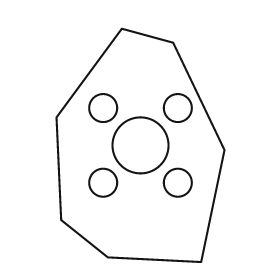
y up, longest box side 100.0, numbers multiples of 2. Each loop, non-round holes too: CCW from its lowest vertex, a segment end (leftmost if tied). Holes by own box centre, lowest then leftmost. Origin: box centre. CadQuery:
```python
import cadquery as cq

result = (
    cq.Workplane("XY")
    .moveTo(26.0, -50.0)
    .lineTo(36.0, -2.0)
    .lineTo(14.0, 44.0)
    .lineTo(-8.0, 50.0)
    .lineTo(-36.0, 12.0)
    .lineTo(-34.0, -32.0)
    .lineTo(-14.0, -48.0)
    .close()
    .moveTo(-16.0, -16.0)
    .circle(6.0)
    .moveTo(16.0, -16.0)
    .circle(6.0)
    .moveTo(0.0, 0.0)
    .circle(12.0)
    .moveTo(-16.0, 16.0)
    .circle(6.0)
    .moveTo(16.0, 16.0)
    .circle(6.0)
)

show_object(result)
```